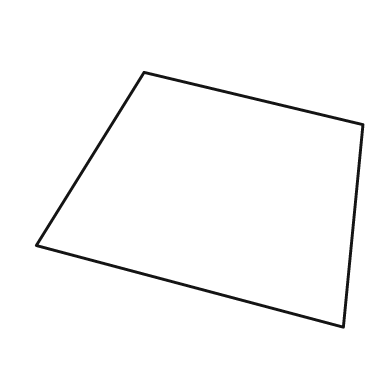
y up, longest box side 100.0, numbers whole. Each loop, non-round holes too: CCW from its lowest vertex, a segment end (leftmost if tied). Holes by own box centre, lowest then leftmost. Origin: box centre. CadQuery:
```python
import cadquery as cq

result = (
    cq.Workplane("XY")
    .moveTo(44.0, -39.0)
    .lineTo(50.0, 23.0)
    .lineTo(-17.0, 39.0)
    .lineTo(-50.0, -14.0)
    .close()
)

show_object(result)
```